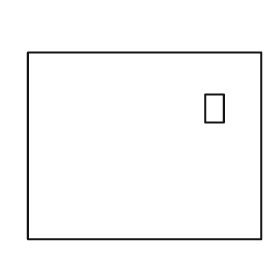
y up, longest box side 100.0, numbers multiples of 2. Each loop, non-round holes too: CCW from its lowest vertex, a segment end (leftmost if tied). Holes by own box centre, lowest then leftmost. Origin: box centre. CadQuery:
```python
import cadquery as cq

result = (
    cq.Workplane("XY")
    .moveTo(-50.0, -40.0)
    .lineTo(50.0, -40.0)
    .lineTo(50.0, 40.0)
    .lineTo(-50.0, 40.0)
    .close()
    .moveTo(26.0, 10.0)
    .lineTo(34.0, 10.0)
    .lineTo(34.0, 22.0)
    .lineTo(26.0, 22.0)
    .close()
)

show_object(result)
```